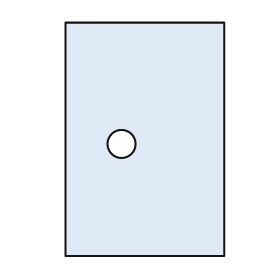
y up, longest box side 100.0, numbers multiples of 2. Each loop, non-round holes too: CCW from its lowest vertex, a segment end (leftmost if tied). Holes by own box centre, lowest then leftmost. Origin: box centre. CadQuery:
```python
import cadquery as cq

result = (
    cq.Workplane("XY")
    .moveTo(-34.0, -50.0)
    .lineTo(34.0, -50.0)
    .lineTo(34.0, 50.0)
    .lineTo(-34.0, 50.0)
    .close()
    .moveTo(-10.0, -2.0)
    .circle(6.0)
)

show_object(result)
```